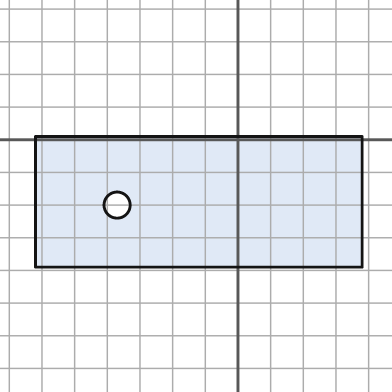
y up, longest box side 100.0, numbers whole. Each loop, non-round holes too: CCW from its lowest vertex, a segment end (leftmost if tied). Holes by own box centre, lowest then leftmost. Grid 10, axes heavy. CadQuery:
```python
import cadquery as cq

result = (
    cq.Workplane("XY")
    .moveTo(-62.0, -39.0)
    .lineTo(38.0, -39.0)
    .lineTo(38.0, 1.0)
    .lineTo(-62.0, 1.0)
    .close()
    .moveTo(-37.0, -20.0)
    .circle(4.0)
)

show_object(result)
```